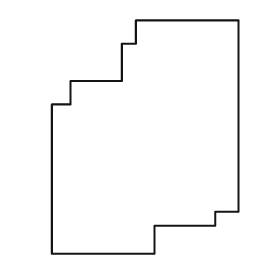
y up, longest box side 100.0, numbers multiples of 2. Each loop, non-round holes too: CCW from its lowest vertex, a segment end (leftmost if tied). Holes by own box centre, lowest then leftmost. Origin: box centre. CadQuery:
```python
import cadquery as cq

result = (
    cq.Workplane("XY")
    .moveTo(-40.0, -50.0)
    .lineTo(4.0, -50.0)
    .lineTo(4.0, -38.0)
    .lineTo(30.0, -38.0)
    .lineTo(30.0, -32.0)
    .lineTo(40.0, -32.0)
    .lineTo(40.0, 50.0)
    .lineTo(-4.0, 50.0)
    .lineTo(-4.0, 40.0)
    .lineTo(-10.0, 40.0)
    .lineTo(-10.0, 24.0)
    .lineTo(-32.0, 24.0)
    .lineTo(-32.0, 14.0)
    .lineTo(-40.0, 14.0)
    .close()
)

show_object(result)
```